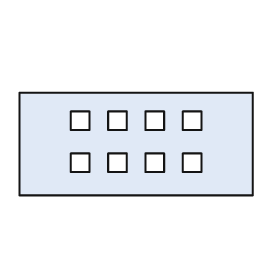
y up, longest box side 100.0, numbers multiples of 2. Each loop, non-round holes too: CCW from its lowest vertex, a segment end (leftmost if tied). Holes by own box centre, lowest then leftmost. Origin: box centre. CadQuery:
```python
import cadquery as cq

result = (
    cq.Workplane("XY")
    .moveTo(-50.0, -22.0)
    .lineTo(50.0, -22.0)
    .lineTo(50.0, 22.0)
    .lineTo(-50.0, 22.0)
    .close()
    .moveTo(-28.0, -12.0)
    .lineTo(-20.0, -12.0)
    .lineTo(-20.0, -4.0)
    .lineTo(-28.0, -4.0)
    .close()
    .moveTo(-12.0, -12.0)
    .lineTo(-4.0, -12.0)
    .lineTo(-4.0, -4.0)
    .lineTo(-12.0, -4.0)
    .close()
    .moveTo(4.0, -12.0)
    .lineTo(12.0, -12.0)
    .lineTo(12.0, -4.0)
    .lineTo(4.0, -4.0)
    .close()
    .moveTo(20.0, -12.0)
    .lineTo(28.0, -12.0)
    .lineTo(28.0, -4.0)
    .lineTo(20.0, -4.0)
    .close()
    .moveTo(-28.0, 6.0)
    .lineTo(-20.0, 6.0)
    .lineTo(-20.0, 14.0)
    .lineTo(-28.0, 14.0)
    .close()
    .moveTo(-12.0, 6.0)
    .lineTo(-4.0, 6.0)
    .lineTo(-4.0, 14.0)
    .lineTo(-12.0, 14.0)
    .close()
    .moveTo(4.0, 6.0)
    .lineTo(12.0, 6.0)
    .lineTo(12.0, 14.0)
    .lineTo(4.0, 14.0)
    .close()
    .moveTo(20.0, 6.0)
    .lineTo(28.0, 6.0)
    .lineTo(28.0, 14.0)
    .lineTo(20.0, 14.0)
    .close()
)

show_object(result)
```